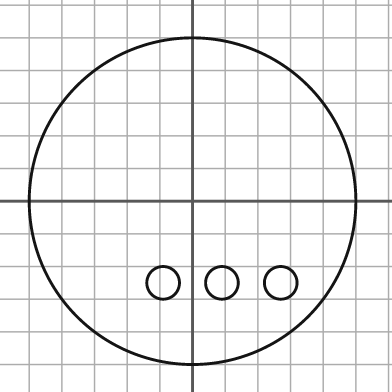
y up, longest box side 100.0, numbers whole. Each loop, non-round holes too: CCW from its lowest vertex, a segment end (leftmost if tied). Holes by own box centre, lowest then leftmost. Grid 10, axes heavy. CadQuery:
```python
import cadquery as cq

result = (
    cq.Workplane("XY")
    .moveTo(0.0, 0.0)
    .circle(50.0)
    .moveTo(-9.0, -25.0)
    .circle(5.0)
    .moveTo(9.0, -25.0)
    .circle(5.0)
    .moveTo(27.0, -25.0)
    .circle(5.0)
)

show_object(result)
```